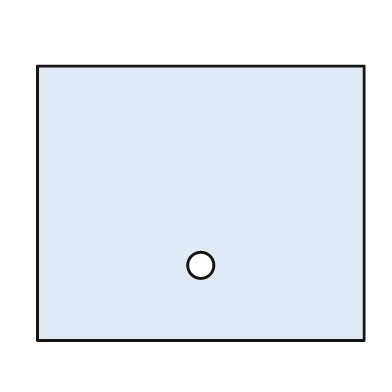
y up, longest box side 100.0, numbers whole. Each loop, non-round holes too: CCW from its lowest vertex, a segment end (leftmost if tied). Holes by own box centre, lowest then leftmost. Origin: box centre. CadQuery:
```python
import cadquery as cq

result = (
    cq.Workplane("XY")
    .moveTo(-50.0, -42.0)
    .lineTo(50.0, -42.0)
    .lineTo(50.0, 42.0)
    .lineTo(-50.0, 42.0)
    .close()
    .moveTo(0.0, -19.0)
    .circle(4.0)
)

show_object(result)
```